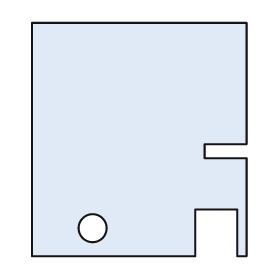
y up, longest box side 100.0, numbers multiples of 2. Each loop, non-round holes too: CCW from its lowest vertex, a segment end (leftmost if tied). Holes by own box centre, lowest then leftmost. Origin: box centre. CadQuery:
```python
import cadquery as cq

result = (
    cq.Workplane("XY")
    .moveTo(-46.0, -50.0)
    .lineTo(24.0, -50.0)
    .lineTo(24.0, -30.0)
    .lineTo(42.0, -30.0)
    .lineTo(42.0, -50.0)
    .lineTo(46.0, -50.0)
    .lineTo(46.0, -8.0)
    .lineTo(28.0, -8.0)
    .lineTo(28.0, -2.0)
    .lineTo(46.0, -2.0)
    .lineTo(46.0, 50.0)
    .lineTo(-46.0, 50.0)
    .close()
    .moveTo(-20.0, -38.0)
    .circle(6.0)
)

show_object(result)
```